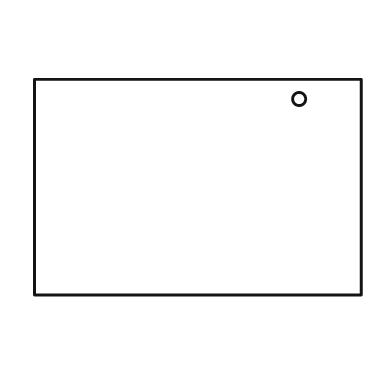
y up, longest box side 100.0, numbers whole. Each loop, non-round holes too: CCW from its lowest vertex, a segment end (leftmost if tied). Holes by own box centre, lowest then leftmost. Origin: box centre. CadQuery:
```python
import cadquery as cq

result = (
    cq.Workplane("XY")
    .moveTo(-50.0, -33.0)
    .lineTo(50.0, -33.0)
    .lineTo(50.0, 33.0)
    .lineTo(-50.0, 33.0)
    .close()
    .moveTo(31.0, 27.0)
    .circle(2.0)
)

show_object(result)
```